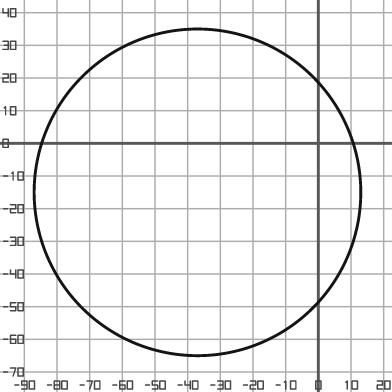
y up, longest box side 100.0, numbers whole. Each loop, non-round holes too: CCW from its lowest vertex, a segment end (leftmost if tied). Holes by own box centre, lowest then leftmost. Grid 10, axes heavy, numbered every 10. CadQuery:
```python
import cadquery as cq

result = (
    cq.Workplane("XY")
    .moveTo(-37.0, -15.0)
    .circle(50.0)
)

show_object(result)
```